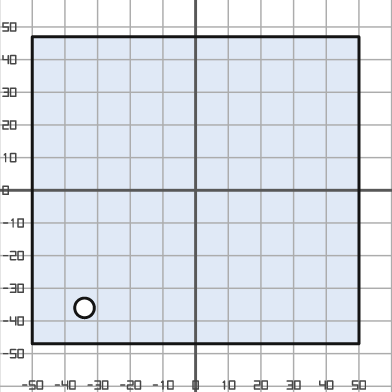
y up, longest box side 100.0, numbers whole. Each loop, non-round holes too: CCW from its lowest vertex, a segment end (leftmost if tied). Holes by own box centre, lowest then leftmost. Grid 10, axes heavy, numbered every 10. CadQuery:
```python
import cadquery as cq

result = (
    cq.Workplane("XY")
    .moveTo(-50.0, -47.0)
    .lineTo(50.0, -47.0)
    .lineTo(50.0, 47.0)
    .lineTo(-50.0, 47.0)
    .close()
    .moveTo(-34.0, -36.0)
    .circle(3.0)
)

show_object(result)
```